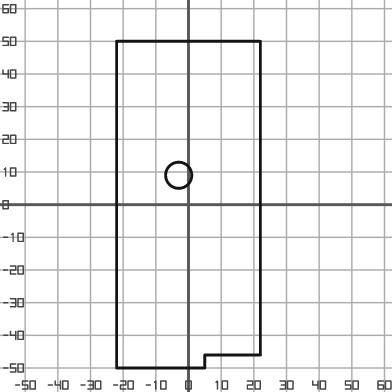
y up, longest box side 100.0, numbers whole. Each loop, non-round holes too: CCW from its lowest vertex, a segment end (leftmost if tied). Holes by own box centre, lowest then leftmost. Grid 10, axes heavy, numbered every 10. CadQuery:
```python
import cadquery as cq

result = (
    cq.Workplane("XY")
    .moveTo(-22.0, -50.0)
    .lineTo(5.0, -50.0)
    .lineTo(5.0, -46.0)
    .lineTo(22.0, -46.0)
    .lineTo(22.0, 50.0)
    .lineTo(-22.0, 50.0)
    .close()
    .moveTo(-3.0, 9.0)
    .circle(4.0)
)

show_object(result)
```